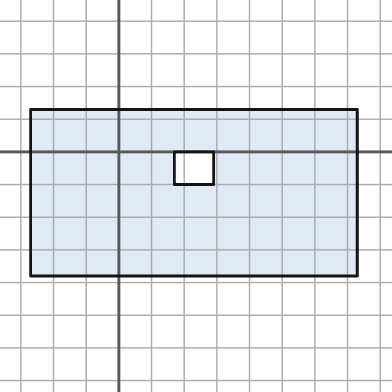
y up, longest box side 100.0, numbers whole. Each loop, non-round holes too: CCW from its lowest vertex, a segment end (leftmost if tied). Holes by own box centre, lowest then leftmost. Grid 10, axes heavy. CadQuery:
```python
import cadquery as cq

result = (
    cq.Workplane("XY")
    .moveTo(-27.0, -38.0)
    .lineTo(73.0, -38.0)
    .lineTo(73.0, 13.0)
    .lineTo(-27.0, 13.0)
    .close()
    .moveTo(17.0, -10.0)
    .lineTo(29.0, -10.0)
    .lineTo(29.0, 0.0)
    .lineTo(17.0, 0.0)
    .close()
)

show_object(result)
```